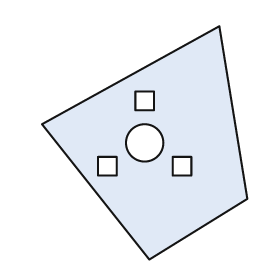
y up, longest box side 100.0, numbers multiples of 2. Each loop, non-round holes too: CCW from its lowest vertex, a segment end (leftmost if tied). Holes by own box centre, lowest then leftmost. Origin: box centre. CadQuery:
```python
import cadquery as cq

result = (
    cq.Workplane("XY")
    .moveTo(2.0, -50.0)
    .lineTo(44.0, -24.0)
    .lineTo(32.0, 50.0)
    .lineTo(-44.0, 8.0)
    .close()
    .moveTo(-20.0, -14.0)
    .lineTo(-12.0, -14.0)
    .lineTo(-12.0, -6.0)
    .lineTo(-20.0, -6.0)
    .close()
    .moveTo(12.0, -14.0)
    .lineTo(20.0, -14.0)
    .lineTo(20.0, -6.0)
    .lineTo(12.0, -6.0)
    .close()
    .moveTo(0.0, 0.0)
    .circle(8.0)
    .moveTo(-4.0, 14.0)
    .lineTo(4.0, 14.0)
    .lineTo(4.0, 22.0)
    .lineTo(-4.0, 22.0)
    .close()
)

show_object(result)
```